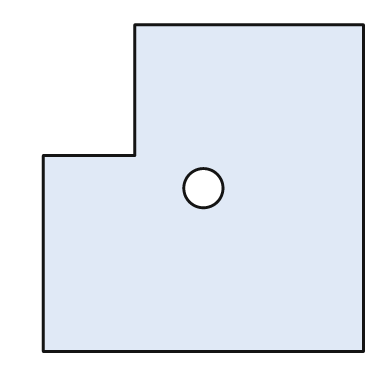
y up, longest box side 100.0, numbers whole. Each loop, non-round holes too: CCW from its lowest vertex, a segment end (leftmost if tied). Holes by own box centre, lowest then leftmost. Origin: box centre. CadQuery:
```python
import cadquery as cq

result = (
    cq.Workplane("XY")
    .moveTo(-49.0, -50.0)
    .lineTo(49.0, -50.0)
    .lineTo(49.0, 50.0)
    .lineTo(-21.0, 50.0)
    .lineTo(-21.0, 10.0)
    .lineTo(-49.0, 10.0)
    .close()
    .moveTo(0.0, 0.0)
    .circle(6.0)
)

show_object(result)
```